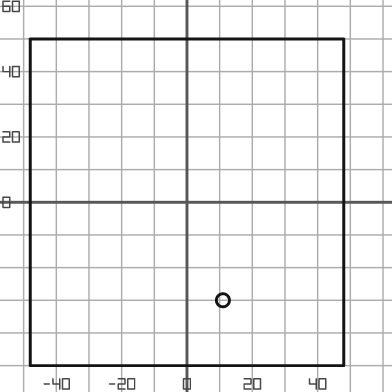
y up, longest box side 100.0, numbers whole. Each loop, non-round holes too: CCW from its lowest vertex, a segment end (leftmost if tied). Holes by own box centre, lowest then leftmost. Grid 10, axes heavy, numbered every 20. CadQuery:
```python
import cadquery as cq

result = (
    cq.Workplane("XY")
    .moveTo(-48.0, -50.0)
    .lineTo(48.0, -50.0)
    .lineTo(48.0, 50.0)
    .lineTo(-48.0, 50.0)
    .close()
    .moveTo(11.0, -30.0)
    .circle(2.0)
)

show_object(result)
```